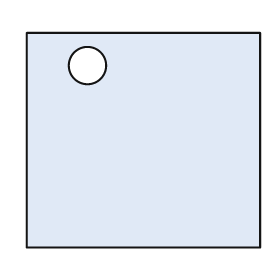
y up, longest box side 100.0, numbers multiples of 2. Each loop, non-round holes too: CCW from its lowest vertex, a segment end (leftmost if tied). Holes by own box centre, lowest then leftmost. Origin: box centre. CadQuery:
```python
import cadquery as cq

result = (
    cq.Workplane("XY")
    .moveTo(-50.0, -46.0)
    .lineTo(50.0, -46.0)
    .lineTo(50.0, 46.0)
    .lineTo(-50.0, 46.0)
    .close()
    .moveTo(-24.0, 32.0)
    .circle(8.0)
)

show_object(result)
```